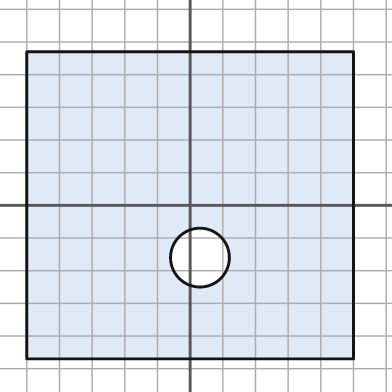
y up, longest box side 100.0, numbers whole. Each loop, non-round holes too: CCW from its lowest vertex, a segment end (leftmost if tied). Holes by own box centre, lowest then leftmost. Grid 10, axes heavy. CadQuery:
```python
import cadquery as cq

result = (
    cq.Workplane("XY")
    .moveTo(-50.0, -47.0)
    .lineTo(50.0, -47.0)
    .lineTo(50.0, 47.0)
    .lineTo(-50.0, 47.0)
    .close()
    .moveTo(3.0, -16.0)
    .circle(9.0)
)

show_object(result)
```